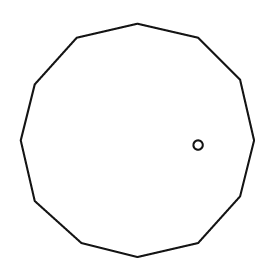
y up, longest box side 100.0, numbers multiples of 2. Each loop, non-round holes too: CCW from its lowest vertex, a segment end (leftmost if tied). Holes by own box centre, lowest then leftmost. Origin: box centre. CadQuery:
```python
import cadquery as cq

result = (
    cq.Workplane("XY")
    .moveTo(0.0, -50.0)
    .lineTo(26.0, -44.0)
    .lineTo(44.0, -24.0)
    .lineTo(50.0, 0.0)
    .lineTo(44.0, 26.0)
    .lineTo(26.0, 44.0)
    .lineTo(0.0, 50.0)
    .lineTo(-26.0, 44.0)
    .lineTo(-44.0, 24.0)
    .lineTo(-50.0, 0.0)
    .lineTo(-44.0, -26.0)
    .lineTo(-24.0, -44.0)
    .close()
    .moveTo(26.0, -2.0)
    .circle(2.0)
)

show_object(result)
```